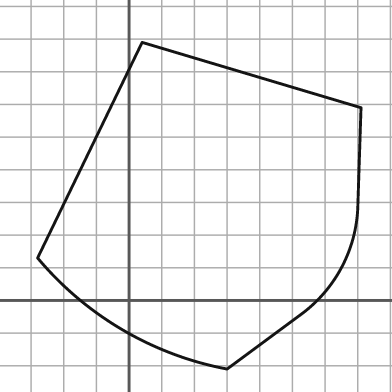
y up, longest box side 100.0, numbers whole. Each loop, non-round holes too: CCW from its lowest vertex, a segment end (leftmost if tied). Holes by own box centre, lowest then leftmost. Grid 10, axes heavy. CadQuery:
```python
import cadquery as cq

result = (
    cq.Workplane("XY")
    .moveTo(30.0, -21.0)
    .lineTo(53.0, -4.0)
    .threePointArc((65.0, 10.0), (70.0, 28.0))
    .lineTo(71.0, 59.0)
    .lineTo(4.0, 79.0)
    .lineTo(-28.0, 13.0)
    .threePointArc((-2.0, -9.0), (30.0, -21.0))
    .close()
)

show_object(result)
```